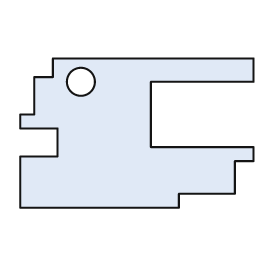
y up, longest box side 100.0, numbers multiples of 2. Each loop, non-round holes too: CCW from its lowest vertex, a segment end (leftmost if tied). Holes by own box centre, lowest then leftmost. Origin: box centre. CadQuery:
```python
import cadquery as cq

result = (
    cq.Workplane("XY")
    .moveTo(-50.0, -32.0)
    .lineTo(18.0, -32.0)
    .lineTo(18.0, -26.0)
    .lineTo(42.0, -26.0)
    .lineTo(42.0, -12.0)
    .lineTo(50.0, -12.0)
    .lineTo(50.0, -6.0)
    .lineTo(6.0, -6.0)
    .lineTo(6.0, 22.0)
    .lineTo(50.0, 22.0)
    .lineTo(50.0, 32.0)
    .lineTo(-36.0, 32.0)
    .lineTo(-36.0, 24.0)
    .lineTo(-44.0, 24.0)
    .lineTo(-44.0, 8.0)
    .lineTo(-50.0, 8.0)
    .lineTo(-50.0, 2.0)
    .lineTo(-34.0, 2.0)
    .lineTo(-34.0, -10.0)
    .lineTo(-50.0, -10.0)
    .close()
    .moveTo(-24.0, 22.0)
    .circle(6.0)
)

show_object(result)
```